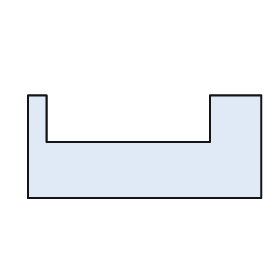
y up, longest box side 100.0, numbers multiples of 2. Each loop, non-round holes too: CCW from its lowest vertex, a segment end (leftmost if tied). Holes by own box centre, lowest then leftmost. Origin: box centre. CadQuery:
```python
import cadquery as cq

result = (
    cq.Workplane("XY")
    .moveTo(-50.0, -22.0)
    .lineTo(50.0, -22.0)
    .lineTo(50.0, 22.0)
    .lineTo(28.0, 22.0)
    .lineTo(28.0, 2.0)
    .lineTo(-42.0, 2.0)
    .lineTo(-42.0, 22.0)
    .lineTo(-50.0, 22.0)
    .close()
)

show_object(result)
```